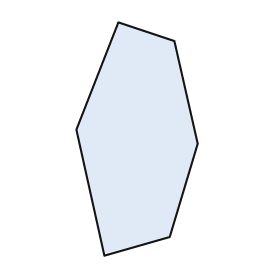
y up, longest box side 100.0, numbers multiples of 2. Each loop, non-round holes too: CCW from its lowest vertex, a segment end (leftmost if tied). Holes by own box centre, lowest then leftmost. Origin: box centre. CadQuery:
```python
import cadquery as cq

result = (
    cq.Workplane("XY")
    .moveTo(-14.0, -50.0)
    .lineTo(14.0, -42.0)
    .lineTo(26.0, -2.0)
    .lineTo(16.0, 42.0)
    .lineTo(-8.0, 50.0)
    .lineTo(-26.0, 4.0)
    .close()
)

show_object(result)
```